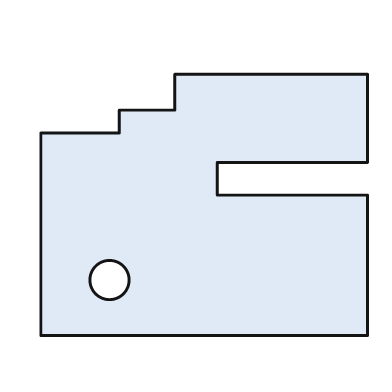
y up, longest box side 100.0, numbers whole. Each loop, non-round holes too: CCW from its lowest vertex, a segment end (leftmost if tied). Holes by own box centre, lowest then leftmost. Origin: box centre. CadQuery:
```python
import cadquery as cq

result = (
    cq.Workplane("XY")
    .moveTo(-50.0, -40.0)
    .lineTo(50.0, -40.0)
    .lineTo(50.0, 3.0)
    .lineTo(4.0, 3.0)
    .lineTo(4.0, 13.0)
    .lineTo(50.0, 13.0)
    .lineTo(50.0, 40.0)
    .lineTo(-9.0, 40.0)
    .lineTo(-9.0, 29.0)
    .lineTo(-26.0, 29.0)
    .lineTo(-26.0, 22.0)
    .lineTo(-50.0, 22.0)
    .close()
    .moveTo(-29.0, -23.0)
    .circle(6.0)
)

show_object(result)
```